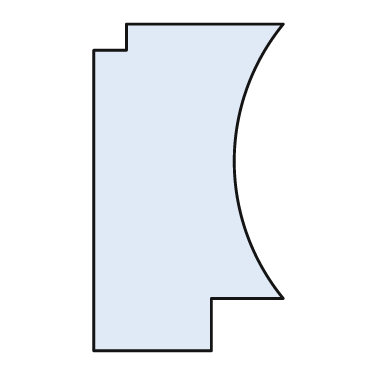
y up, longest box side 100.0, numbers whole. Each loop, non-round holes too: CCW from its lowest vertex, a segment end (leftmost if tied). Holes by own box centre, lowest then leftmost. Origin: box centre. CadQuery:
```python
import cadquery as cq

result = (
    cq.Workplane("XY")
    .moveTo(-29.0, -50.0)
    .lineTo(7.0, -50.0)
    .lineTo(7.0, -34.0)
    .lineTo(29.0, -34.0)
    .threePointArc((14.0, 8.0), (29.0, 50.0))
    .lineTo(-19.0, 50.0)
    .lineTo(-19.0, 42.0)
    .lineTo(-29.0, 42.0)
    .close()
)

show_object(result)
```